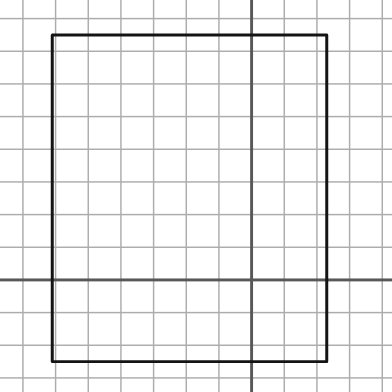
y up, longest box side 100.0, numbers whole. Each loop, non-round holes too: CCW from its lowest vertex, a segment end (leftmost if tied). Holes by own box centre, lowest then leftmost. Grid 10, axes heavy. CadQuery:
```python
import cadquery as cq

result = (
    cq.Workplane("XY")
    .moveTo(-61.0, -25.0)
    .lineTo(23.0, -25.0)
    .lineTo(23.0, 75.0)
    .lineTo(-61.0, 75.0)
    .close()
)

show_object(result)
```